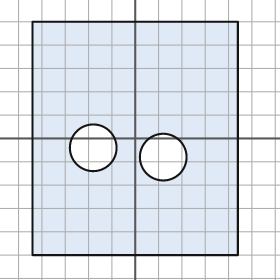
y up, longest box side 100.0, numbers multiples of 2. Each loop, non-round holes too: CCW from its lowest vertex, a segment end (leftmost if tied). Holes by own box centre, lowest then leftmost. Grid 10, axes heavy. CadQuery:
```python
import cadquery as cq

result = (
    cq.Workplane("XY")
    .moveTo(-44.0, -50.0)
    .lineTo(44.0, -50.0)
    .lineTo(44.0, 50.0)
    .lineTo(-44.0, 50.0)
    .close()
    .moveTo(12.0, -8.0)
    .circle(10.0)
    .moveTo(-18.0, -4.0)
    .circle(10.0)
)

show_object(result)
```